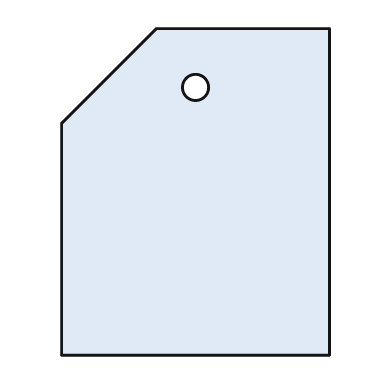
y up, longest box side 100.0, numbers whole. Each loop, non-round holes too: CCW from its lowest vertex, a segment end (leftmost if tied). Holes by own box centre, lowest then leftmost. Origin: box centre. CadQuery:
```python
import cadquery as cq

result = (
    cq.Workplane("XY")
    .moveTo(-41.0, -50.0)
    .lineTo(41.0, -50.0)
    .lineTo(41.0, 50.0)
    .lineTo(-12.0, 50.0)
    .lineTo(-41.0, 21.0)
    .close()
    .moveTo(0.0, 32.0)
    .circle(4.0)
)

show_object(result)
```